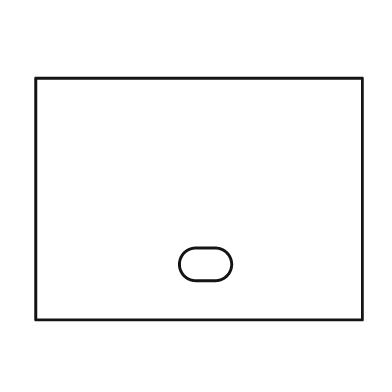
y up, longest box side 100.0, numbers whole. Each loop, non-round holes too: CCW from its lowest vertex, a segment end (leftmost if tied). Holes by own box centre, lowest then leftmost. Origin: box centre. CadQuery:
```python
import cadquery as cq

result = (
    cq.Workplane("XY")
    .moveTo(-50.0, -37.0)
    .lineTo(50.0, -37.0)
    .lineTo(50.0, 37.0)
    .lineTo(-50.0, 37.0)
    .close()
    .moveTo(-1.0, -25.0)
    .lineTo(5.0, -25.0)
    .threePointArc((10.0, -20.0), (5.0, -15.0))
    .lineTo(-1.0, -15.0)
    .threePointArc((-6.0, -20.0), (-1.0, -25.0))
    .close()
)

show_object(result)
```